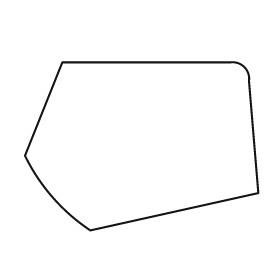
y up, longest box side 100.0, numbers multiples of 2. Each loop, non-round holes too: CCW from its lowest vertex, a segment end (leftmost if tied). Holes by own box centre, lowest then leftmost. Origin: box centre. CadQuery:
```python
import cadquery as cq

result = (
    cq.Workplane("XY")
    .moveTo(-22.0, -36.0)
    .lineTo(50.0, -20.0)
    .lineTo(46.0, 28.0)
    .threePointArc((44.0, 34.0), (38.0, 36.0))
    .lineTo(-34.0, 36.0)
    .lineTo(-50.0, -4.0)
    .threePointArc((-38.0, -22.0), (-22.0, -36.0))
    .close()
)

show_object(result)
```